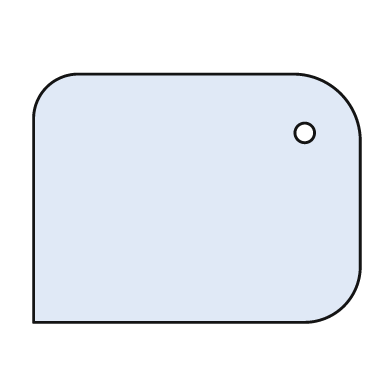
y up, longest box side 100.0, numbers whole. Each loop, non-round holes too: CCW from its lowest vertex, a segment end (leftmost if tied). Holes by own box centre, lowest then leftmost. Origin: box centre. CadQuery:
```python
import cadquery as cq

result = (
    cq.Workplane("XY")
    .moveTo(-50.0, -38.0)
    .lineTo(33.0, -38.0)
    .threePointArc((45.0, -33.0), (50.0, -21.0))
    .lineTo(50.0, 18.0)
    .threePointArc((44.0, 32.0), (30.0, 38.0))
    .lineTo(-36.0, 38.0)
    .threePointArc((-46.0, 34.0), (-50.0, 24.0))
    .close()
    .moveTo(33.0, 20.0)
    .circle(3.0)
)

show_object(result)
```